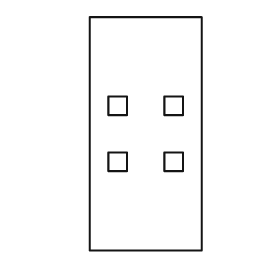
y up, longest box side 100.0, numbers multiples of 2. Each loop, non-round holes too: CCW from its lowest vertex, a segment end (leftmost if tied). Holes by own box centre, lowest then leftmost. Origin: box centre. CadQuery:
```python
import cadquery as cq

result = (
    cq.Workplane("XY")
    .moveTo(-24.0, -50.0)
    .lineTo(24.0, -50.0)
    .lineTo(24.0, 50.0)
    .lineTo(-24.0, 50.0)
    .close()
    .moveTo(-16.0, -16.0)
    .lineTo(-8.0, -16.0)
    .lineTo(-8.0, -8.0)
    .lineTo(-16.0, -8.0)
    .close()
    .moveTo(8.0, -16.0)
    .lineTo(16.0, -16.0)
    .lineTo(16.0, -8.0)
    .lineTo(8.0, -8.0)
    .close()
    .moveTo(-16.0, 8.0)
    .lineTo(-8.0, 8.0)
    .lineTo(-8.0, 16.0)
    .lineTo(-16.0, 16.0)
    .close()
    .moveTo(8.0, 8.0)
    .lineTo(16.0, 8.0)
    .lineTo(16.0, 16.0)
    .lineTo(8.0, 16.0)
    .close()
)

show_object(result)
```